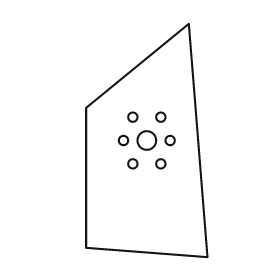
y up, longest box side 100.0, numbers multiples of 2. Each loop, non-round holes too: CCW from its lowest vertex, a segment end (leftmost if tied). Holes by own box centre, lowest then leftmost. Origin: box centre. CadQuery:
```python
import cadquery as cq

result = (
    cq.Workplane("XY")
    .moveTo(26.0, -50.0)
    .lineTo(18.0, 50.0)
    .lineTo(-26.0, 14.0)
    .lineTo(-26.0, -46.0)
    .close()
    .moveTo(-6.0, -10.0)
    .circle(2.0)
    .moveTo(6.0, -10.0)
    .circle(2.0)
    .moveTo(-10.0, 0.0)
    .circle(2.0)
    .moveTo(0.0, 0.0)
    .circle(4.0)
    .moveTo(10.0, 0.0)
    .circle(2.0)
    .moveTo(-6.0, 10.0)
    .circle(2.0)
    .moveTo(6.0, 10.0)
    .circle(2.0)
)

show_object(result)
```